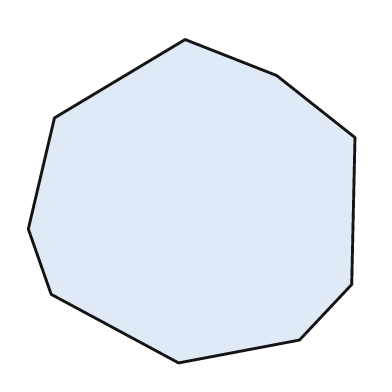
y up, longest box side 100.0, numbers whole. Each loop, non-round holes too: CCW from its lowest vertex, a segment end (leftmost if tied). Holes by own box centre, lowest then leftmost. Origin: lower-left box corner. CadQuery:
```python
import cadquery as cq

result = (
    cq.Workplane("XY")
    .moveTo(46.0, 0.0)
    .lineTo(83.0, 7.0)
    .lineTo(99.0, 24.0)
    .lineTo(100.0, 69.0)
    .lineTo(76.0, 88.0)
    .lineTo(48.0, 99.0)
    .lineTo(8.0, 75.0)
    .lineTo(0.0, 41.0)
    .lineTo(7.0, 21.0)
    .close()
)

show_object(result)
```